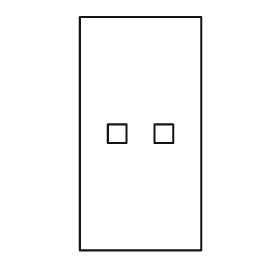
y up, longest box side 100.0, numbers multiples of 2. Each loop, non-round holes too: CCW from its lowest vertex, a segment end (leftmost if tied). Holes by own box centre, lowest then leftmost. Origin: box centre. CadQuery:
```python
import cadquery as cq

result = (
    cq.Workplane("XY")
    .moveTo(-26.0, -50.0)
    .lineTo(26.0, -50.0)
    .lineTo(26.0, 50.0)
    .lineTo(-26.0, 50.0)
    .close()
    .moveTo(-14.0, -4.0)
    .lineTo(-6.0, -4.0)
    .lineTo(-6.0, 4.0)
    .lineTo(-14.0, 4.0)
    .close()
    .moveTo(6.0, -4.0)
    .lineTo(14.0, -4.0)
    .lineTo(14.0, 4.0)
    .lineTo(6.0, 4.0)
    .close()
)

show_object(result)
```